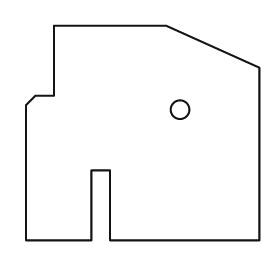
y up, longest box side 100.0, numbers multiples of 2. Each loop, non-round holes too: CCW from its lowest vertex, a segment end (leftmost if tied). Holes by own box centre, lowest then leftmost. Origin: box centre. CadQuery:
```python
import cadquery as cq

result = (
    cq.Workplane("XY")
    .moveTo(-50.0, -46.0)
    .lineTo(-22.0, -46.0)
    .lineTo(-22.0, -16.0)
    .lineTo(-14.0, -16.0)
    .lineTo(-14.0, -46.0)
    .lineTo(50.0, -46.0)
    .lineTo(50.0, 28.0)
    .lineTo(10.0, 46.0)
    .lineTo(-38.0, 46.0)
    .lineTo(-38.0, 16.0)
    .lineTo(-46.0, 16.0)
    .lineTo(-50.0, 12.0)
    .close()
    .moveTo(16.0, 10.0)
    .circle(4.0)
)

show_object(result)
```